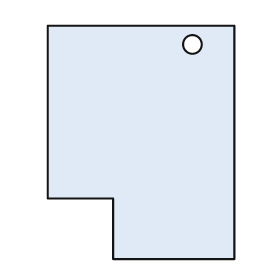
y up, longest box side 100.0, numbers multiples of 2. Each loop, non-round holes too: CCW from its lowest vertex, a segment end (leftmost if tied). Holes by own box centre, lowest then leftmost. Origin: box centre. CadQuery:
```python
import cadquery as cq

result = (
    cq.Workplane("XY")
    .moveTo(-12.0, -50.0)
    .lineTo(40.0, -50.0)
    .lineTo(40.0, 50.0)
    .lineTo(-40.0, 50.0)
    .lineTo(-40.0, -24.0)
    .lineTo(-12.0, -24.0)
    .close()
    .moveTo(22.0, 42.0)
    .circle(4.0)
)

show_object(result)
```